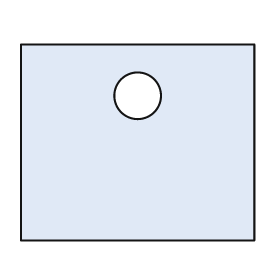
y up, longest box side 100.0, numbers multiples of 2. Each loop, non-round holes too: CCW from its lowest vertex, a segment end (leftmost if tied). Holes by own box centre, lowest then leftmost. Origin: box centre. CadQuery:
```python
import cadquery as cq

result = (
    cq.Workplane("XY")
    .moveTo(-50.0, -42.0)
    .lineTo(50.0, -42.0)
    .lineTo(50.0, 42.0)
    .lineTo(-50.0, 42.0)
    .close()
    .moveTo(0.0, 20.0)
    .circle(10.0)
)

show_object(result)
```